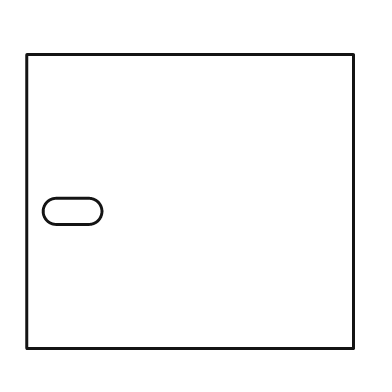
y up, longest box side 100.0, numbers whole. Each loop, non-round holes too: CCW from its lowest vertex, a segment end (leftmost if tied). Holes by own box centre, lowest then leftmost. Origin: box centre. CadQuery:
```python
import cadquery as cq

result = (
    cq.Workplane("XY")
    .moveTo(-50.0, -45.0)
    .lineTo(50.0, -45.0)
    .lineTo(50.0, 45.0)
    .lineTo(-50.0, 45.0)
    .close()
    .moveTo(-41.0, -7.0)
    .lineTo(-31.0, -7.0)
    .threePointArc((-27.0, -3.0), (-31.0, 1.0))
    .lineTo(-41.0, 1.0)
    .threePointArc((-45.0, -3.0), (-41.0, -7.0))
    .close()
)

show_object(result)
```